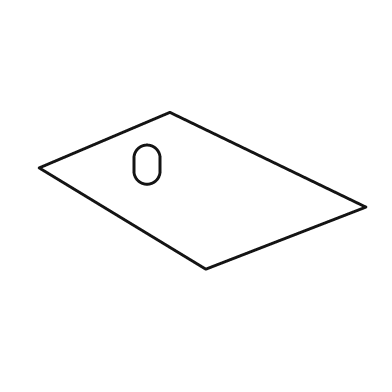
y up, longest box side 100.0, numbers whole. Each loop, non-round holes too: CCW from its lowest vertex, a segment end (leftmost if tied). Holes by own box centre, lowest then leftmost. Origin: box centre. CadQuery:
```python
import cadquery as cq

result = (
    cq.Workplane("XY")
    .moveTo(1.0, -24.0)
    .lineTo(50.0, -5.0)
    .lineTo(-10.0, 24.0)
    .lineTo(-50.0, 7.0)
    .close()
    .moveTo(-21.0, 6.0)
    .threePointArc((-17.0, 2.0), (-13.0, 6.0))
    .lineTo(-13.0, 10.0)
    .threePointArc((-17.0, 14.0), (-21.0, 10.0))
    .close()
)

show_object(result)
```